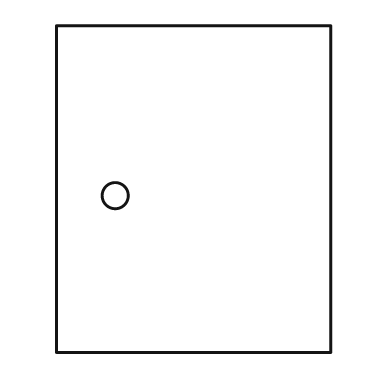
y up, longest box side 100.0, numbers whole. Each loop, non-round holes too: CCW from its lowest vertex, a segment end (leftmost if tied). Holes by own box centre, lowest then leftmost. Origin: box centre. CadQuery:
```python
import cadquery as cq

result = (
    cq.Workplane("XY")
    .moveTo(-42.0, -50.0)
    .lineTo(42.0, -50.0)
    .lineTo(42.0, 50.0)
    .lineTo(-42.0, 50.0)
    .close()
    .moveTo(-24.0, -2.0)
    .circle(4.0)
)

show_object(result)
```